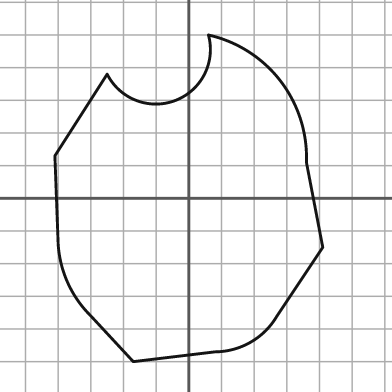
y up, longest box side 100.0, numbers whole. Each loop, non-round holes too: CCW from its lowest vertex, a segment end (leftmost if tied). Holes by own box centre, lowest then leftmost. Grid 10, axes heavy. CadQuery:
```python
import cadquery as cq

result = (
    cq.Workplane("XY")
    .moveTo(-17.0, -50.0)
    .lineTo(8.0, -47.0)
    .threePointArc((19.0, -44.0), (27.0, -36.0))
    .lineTo(41.0, -15.0)
    .lineTo(36.0, 11.0)
    .threePointArc((28.0, 36.0), (6.0, 50.0))
    .threePointArc((-4.0, 30.0), (-25.0, 38.0))
    .lineTo(-41.0, 13.0)
    .lineTo(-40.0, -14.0)
    .threePointArc((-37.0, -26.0), (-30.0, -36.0))
    .close()
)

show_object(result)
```